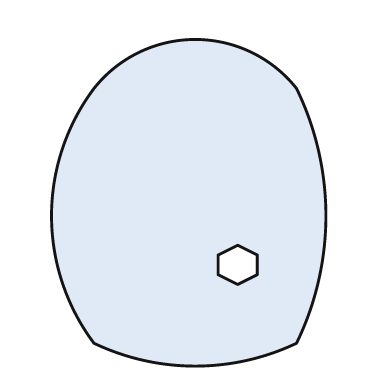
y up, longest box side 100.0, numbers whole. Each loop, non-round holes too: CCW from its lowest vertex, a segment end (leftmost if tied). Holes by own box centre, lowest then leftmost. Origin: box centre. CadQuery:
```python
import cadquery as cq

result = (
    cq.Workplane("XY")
    .moveTo(-29.0, -43.0)
    .threePointArc((2.0, -50.0), (33.0, -43.0))
    .threePointArc((42.0, -4.0), (33.0, 35.0))
    .threePointArc((2.0, 50.0), (-29.0, 35.0))
    .threePointArc((-42.0, -4.0), (-29.0, -43.0))
    .close()
    .moveTo(15.0, -25.0)
    .lineTo(21.0, -22.0)
    .lineTo(21.0, -16.0)
    .lineTo(15.0, -13.0)
    .lineTo(9.0, -16.0)
    .lineTo(9.0, -22.0)
    .close()
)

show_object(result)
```